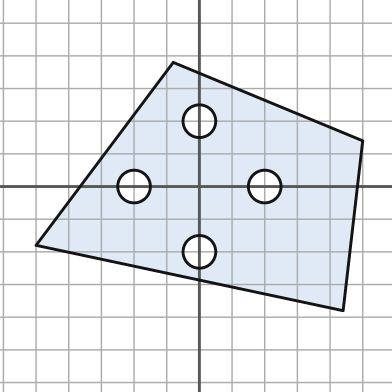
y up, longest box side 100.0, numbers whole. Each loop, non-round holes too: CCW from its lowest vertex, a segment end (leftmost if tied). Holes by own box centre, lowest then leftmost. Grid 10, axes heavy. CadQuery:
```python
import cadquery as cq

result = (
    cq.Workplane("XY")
    .moveTo(44.0, -38.0)
    .lineTo(50.0, 14.0)
    .lineTo(-8.0, 38.0)
    .lineTo(-50.0, -18.0)
    .close()
    .moveTo(0.0, -20.0)
    .circle(5.0)
    .moveTo(-20.0, 0.0)
    .circle(5.0)
    .moveTo(20.0, 0.0)
    .circle(5.0)
    .moveTo(0.0, 20.0)
    .circle(5.0)
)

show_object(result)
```